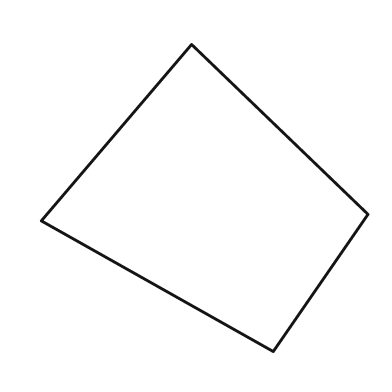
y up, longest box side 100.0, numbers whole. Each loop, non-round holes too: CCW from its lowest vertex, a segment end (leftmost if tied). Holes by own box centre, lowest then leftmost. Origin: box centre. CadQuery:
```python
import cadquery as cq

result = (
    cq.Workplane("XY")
    .moveTo(21.0, -47.0)
    .lineTo(50.0, -5.0)
    .lineTo(-4.0, 47.0)
    .lineTo(-50.0, -7.0)
    .close()
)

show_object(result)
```